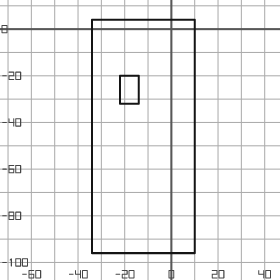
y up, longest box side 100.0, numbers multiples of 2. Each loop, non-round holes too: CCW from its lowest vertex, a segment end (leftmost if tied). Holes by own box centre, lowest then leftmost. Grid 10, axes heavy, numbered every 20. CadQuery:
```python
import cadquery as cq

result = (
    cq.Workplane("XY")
    .moveTo(-34.0, -96.0)
    .lineTo(10.0, -96.0)
    .lineTo(10.0, 4.0)
    .lineTo(-34.0, 4.0)
    .close()
    .moveTo(-22.0, -32.0)
    .lineTo(-14.0, -32.0)
    .lineTo(-14.0, -20.0)
    .lineTo(-22.0, -20.0)
    .close()
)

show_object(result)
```